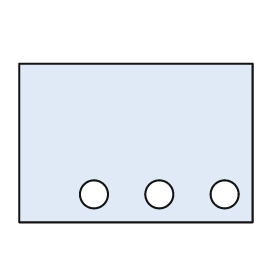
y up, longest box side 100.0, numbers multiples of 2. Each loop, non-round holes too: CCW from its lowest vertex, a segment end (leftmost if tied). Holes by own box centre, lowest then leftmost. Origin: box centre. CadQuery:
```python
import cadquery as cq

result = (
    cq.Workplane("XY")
    .moveTo(-50.0, -34.0)
    .lineTo(50.0, -34.0)
    .lineTo(50.0, 34.0)
    .lineTo(-50.0, 34.0)
    .close()
    .moveTo(-18.0, -22.0)
    .circle(6.0)
    .moveTo(10.0, -22.0)
    .circle(6.0)
    .moveTo(38.0, -22.0)
    .circle(6.0)
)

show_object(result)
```